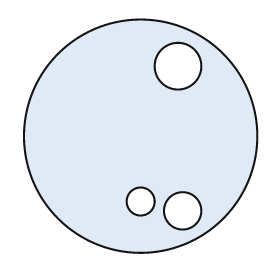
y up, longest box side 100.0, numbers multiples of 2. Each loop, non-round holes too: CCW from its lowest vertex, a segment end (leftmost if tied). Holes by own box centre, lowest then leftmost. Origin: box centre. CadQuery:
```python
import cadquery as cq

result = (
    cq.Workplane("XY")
    .moveTo(0.0, 0.0)
    .circle(50.0)
    .moveTo(18.0, -32.0)
    .circle(8.0)
    .moveTo(0.0, -28.0)
    .circle(6.0)
    .moveTo(16.0, 30.0)
    .circle(10.0)
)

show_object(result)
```